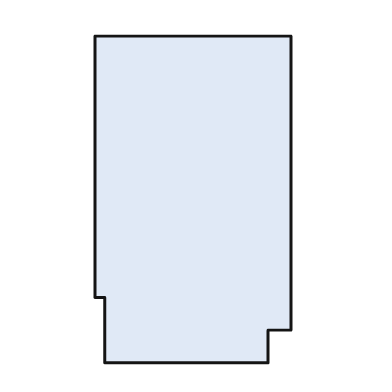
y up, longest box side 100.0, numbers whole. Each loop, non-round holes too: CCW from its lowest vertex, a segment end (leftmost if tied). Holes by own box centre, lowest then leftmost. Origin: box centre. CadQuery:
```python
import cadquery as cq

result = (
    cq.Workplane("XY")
    .moveTo(-27.0, -50.0)
    .lineTo(23.0, -50.0)
    .lineTo(23.0, -40.0)
    .lineTo(30.0, -40.0)
    .lineTo(30.0, 50.0)
    .lineTo(-30.0, 50.0)
    .lineTo(-30.0, -30.0)
    .lineTo(-27.0, -30.0)
    .close()
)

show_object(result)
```